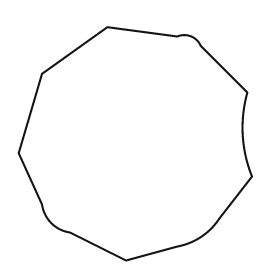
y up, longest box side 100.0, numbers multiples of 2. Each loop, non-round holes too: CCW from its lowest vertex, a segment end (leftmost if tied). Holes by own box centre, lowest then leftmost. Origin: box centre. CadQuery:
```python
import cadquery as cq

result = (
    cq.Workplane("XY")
    .moveTo(-4.0, -50.0)
    .lineTo(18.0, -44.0)
    .threePointArc((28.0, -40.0), (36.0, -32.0))
    .lineTo(50.0, -14.0)
    .threePointArc((46.0, 4.0), (48.0, 22.0))
    .lineTo(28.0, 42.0)
    .threePointArc((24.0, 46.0), (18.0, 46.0))
    .lineTo(-12.0, 50.0)
    .lineTo(-40.0, 30.0)
    .lineTo(-50.0, -4.0)
    .lineTo(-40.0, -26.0)
    .threePointArc((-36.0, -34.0), (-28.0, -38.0))
    .close()
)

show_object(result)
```